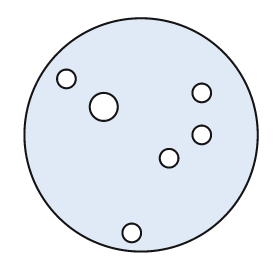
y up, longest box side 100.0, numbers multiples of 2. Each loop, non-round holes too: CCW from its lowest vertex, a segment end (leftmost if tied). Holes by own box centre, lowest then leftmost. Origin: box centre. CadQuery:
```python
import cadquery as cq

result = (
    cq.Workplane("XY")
    .moveTo(0.0, 0.0)
    .circle(50.0)
    .moveTo(-4.0, -42.0)
    .circle(4.0)
    .moveTo(12.0, -10.0)
    .circle(4.0)
    .moveTo(26.0, 0.0)
    .circle(4.0)
    .moveTo(-16.0, 12.0)
    .circle(6.0)
    .moveTo(26.0, 18.0)
    .circle(4.0)
    .moveTo(-32.0, 24.0)
    .circle(4.0)
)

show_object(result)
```